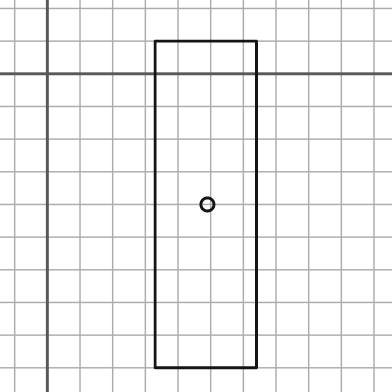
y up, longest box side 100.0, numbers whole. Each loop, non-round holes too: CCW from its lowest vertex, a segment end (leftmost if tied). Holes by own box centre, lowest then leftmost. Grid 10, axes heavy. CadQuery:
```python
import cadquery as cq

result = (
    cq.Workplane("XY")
    .moveTo(33.0, -90.0)
    .lineTo(64.0, -90.0)
    .lineTo(64.0, 10.0)
    .lineTo(33.0, 10.0)
    .close()
    .moveTo(49.0, -40.0)
    .circle(2.0)
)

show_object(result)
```